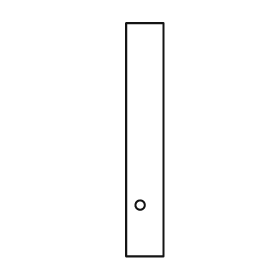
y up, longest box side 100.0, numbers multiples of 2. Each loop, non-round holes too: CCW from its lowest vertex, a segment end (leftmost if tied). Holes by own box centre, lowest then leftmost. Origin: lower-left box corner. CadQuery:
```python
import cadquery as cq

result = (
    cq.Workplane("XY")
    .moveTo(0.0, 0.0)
    .lineTo(16.0, 0.0)
    .lineTo(16.0, 100.0)
    .lineTo(0.0, 100.0)
    .close()
    .moveTo(6.0, 22.0)
    .circle(2.0)
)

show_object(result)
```